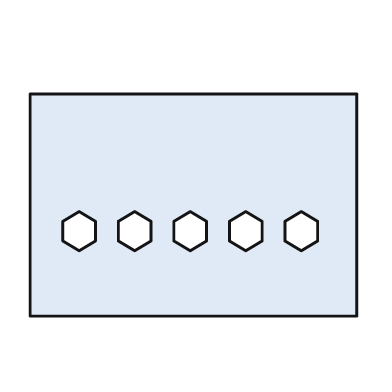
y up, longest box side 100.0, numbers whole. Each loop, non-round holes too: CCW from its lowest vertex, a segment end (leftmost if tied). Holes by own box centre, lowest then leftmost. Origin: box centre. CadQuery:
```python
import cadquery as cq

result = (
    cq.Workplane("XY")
    .moveTo(-50.0, -34.0)
    .lineTo(50.0, -34.0)
    .lineTo(50.0, 34.0)
    .lineTo(-50.0, 34.0)
    .close()
    .moveTo(-35.0, -14.0)
    .lineTo(-30.0, -11.0)
    .lineTo(-30.0, -5.0)
    .lineTo(-35.0, -2.0)
    .lineTo(-40.0, -5.0)
    .lineTo(-40.0, -11.0)
    .close()
    .moveTo(-18.0, -14.0)
    .lineTo(-13.0, -11.0)
    .lineTo(-13.0, -5.0)
    .lineTo(-18.0, -2.0)
    .lineTo(-23.0, -5.0)
    .lineTo(-23.0, -11.0)
    .close()
    .moveTo(-1.0, -14.0)
    .lineTo(4.0, -11.0)
    .lineTo(4.0, -5.0)
    .lineTo(-1.0, -2.0)
    .lineTo(-6.0, -5.0)
    .lineTo(-6.0, -11.0)
    .close()
    .moveTo(16.0, -14.0)
    .lineTo(21.0, -11.0)
    .lineTo(21.0, -5.0)
    .lineTo(16.0, -2.0)
    .lineTo(11.0, -5.0)
    .lineTo(11.0, -11.0)
    .close()
    .moveTo(33.0, -14.0)
    .lineTo(38.0, -11.0)
    .lineTo(38.0, -5.0)
    .lineTo(33.0, -2.0)
    .lineTo(28.0, -5.0)
    .lineTo(28.0, -11.0)
    .close()
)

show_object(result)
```